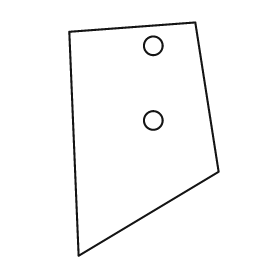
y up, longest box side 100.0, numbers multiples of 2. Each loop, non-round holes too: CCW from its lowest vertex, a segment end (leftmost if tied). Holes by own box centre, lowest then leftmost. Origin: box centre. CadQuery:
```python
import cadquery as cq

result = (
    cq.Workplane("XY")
    .moveTo(-28.0, -50.0)
    .lineTo(32.0, -14.0)
    .lineTo(22.0, 50.0)
    .lineTo(-32.0, 46.0)
    .close()
    .moveTo(4.0, 8.0)
    .circle(4.0)
    .moveTo(4.0, 40.0)
    .circle(4.0)
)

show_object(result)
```